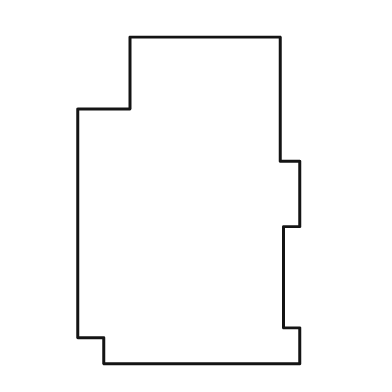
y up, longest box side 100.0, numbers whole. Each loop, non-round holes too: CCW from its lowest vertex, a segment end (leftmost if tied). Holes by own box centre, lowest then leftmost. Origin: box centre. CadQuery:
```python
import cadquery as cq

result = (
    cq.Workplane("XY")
    .moveTo(-26.0, -50.0)
    .lineTo(34.0, -50.0)
    .lineTo(34.0, -39.0)
    .lineTo(29.0, -39.0)
    .lineTo(29.0, -8.0)
    .lineTo(34.0, -8.0)
    .lineTo(34.0, 12.0)
    .lineTo(28.0, 12.0)
    .lineTo(28.0, 50.0)
    .lineTo(-18.0, 50.0)
    .lineTo(-18.0, 28.0)
    .lineTo(-34.0, 28.0)
    .lineTo(-34.0, -42.0)
    .lineTo(-26.0, -42.0)
    .close()
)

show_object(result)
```